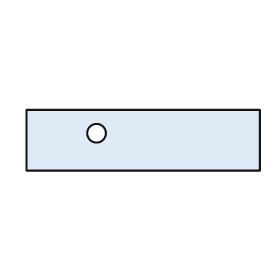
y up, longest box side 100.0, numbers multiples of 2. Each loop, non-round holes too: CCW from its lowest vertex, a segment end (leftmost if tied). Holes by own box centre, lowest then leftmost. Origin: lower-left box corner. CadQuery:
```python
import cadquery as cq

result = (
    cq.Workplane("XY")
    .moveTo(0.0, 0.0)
    .lineTo(100.0, 0.0)
    .lineTo(100.0, 26.0)
    .lineTo(0.0, 26.0)
    .close()
    .moveTo(30.0, 16.0)
    .circle(4.0)
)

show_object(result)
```